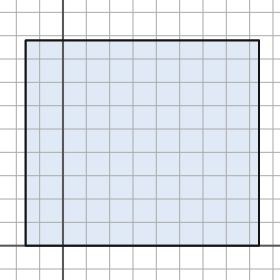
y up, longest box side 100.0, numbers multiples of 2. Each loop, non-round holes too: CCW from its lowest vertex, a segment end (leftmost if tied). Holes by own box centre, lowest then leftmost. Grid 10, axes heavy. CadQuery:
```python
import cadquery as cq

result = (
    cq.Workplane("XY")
    .moveTo(-16.0, 0.0)
    .lineTo(84.0, 0.0)
    .lineTo(84.0, 88.0)
    .lineTo(-16.0, 88.0)
    .close()
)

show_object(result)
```